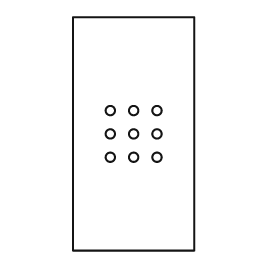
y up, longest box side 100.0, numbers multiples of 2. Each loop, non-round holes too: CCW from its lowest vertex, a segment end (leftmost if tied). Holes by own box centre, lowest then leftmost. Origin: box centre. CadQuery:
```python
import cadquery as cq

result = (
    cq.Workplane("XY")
    .moveTo(-26.0, -50.0)
    .lineTo(26.0, -50.0)
    .lineTo(26.0, 50.0)
    .lineTo(-26.0, 50.0)
    .close()
    .moveTo(-10.0, -10.0)
    .circle(2.0)
    .moveTo(0.0, -10.0)
    .circle(2.0)
    .moveTo(10.0, -10.0)
    .circle(2.0)
    .moveTo(-10.0, 0.0)
    .circle(2.0)
    .moveTo(0.0, 0.0)
    .circle(2.0)
    .moveTo(10.0, 0.0)
    .circle(2.0)
    .moveTo(-10.0, 10.0)
    .circle(2.0)
    .moveTo(0.0, 10.0)
    .circle(2.0)
    .moveTo(10.0, 10.0)
    .circle(2.0)
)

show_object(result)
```